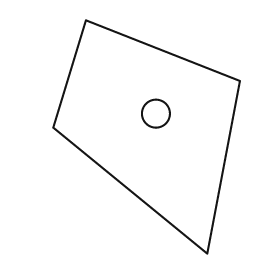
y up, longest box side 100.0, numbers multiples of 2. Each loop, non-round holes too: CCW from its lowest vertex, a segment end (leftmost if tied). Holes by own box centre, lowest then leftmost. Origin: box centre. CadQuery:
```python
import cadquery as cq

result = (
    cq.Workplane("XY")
    .moveTo(26.0, -50.0)
    .lineTo(40.0, 24.0)
    .lineTo(-26.0, 50.0)
    .lineTo(-40.0, 4.0)
    .close()
    .moveTo(4.0, 10.0)
    .circle(6.0)
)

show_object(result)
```